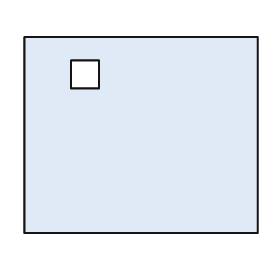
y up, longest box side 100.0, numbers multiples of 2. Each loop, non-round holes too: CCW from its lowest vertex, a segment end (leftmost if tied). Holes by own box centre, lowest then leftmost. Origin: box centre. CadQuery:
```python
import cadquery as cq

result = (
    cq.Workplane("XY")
    .moveTo(-50.0, -42.0)
    .lineTo(50.0, -42.0)
    .lineTo(50.0, 42.0)
    .lineTo(-50.0, 42.0)
    .close()
    .moveTo(-30.0, 20.0)
    .lineTo(-18.0, 20.0)
    .lineTo(-18.0, 32.0)
    .lineTo(-30.0, 32.0)
    .close()
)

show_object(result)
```